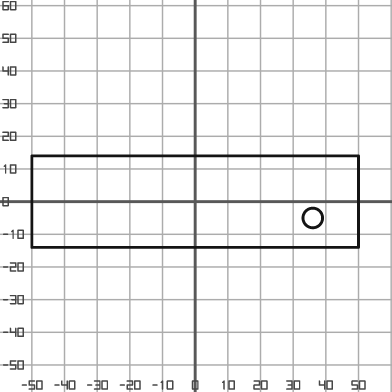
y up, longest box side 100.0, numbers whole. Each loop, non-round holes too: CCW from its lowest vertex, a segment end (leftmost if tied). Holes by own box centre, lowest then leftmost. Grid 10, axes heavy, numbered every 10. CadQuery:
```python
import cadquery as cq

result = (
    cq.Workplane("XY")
    .moveTo(-50.0, -14.0)
    .lineTo(50.0, -14.0)
    .lineTo(50.0, 14.0)
    .lineTo(-50.0, 14.0)
    .close()
    .moveTo(36.0, -5.0)
    .circle(3.0)
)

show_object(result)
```